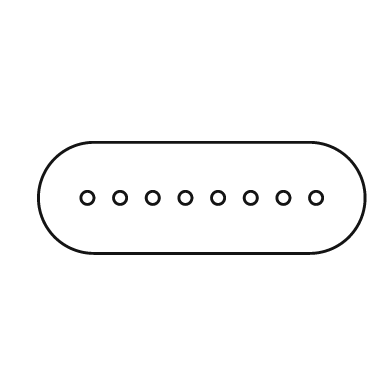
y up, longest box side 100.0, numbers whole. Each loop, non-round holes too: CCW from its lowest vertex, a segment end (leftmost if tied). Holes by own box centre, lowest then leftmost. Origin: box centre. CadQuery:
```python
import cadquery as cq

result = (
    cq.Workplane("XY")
    .moveTo(-33.0, -17.0)
    .lineTo(33.0, -17.0)
    .threePointArc((50.0, 0.0), (33.0, 17.0))
    .lineTo(-33.0, 17.0)
    .threePointArc((-50.0, 0.0), (-33.0, -17.0))
    .close()
    .moveTo(-35.0, 0.0)
    .circle(2.0)
    .moveTo(-25.0, 0.0)
    .circle(2.0)
    .moveTo(-15.0, 0.0)
    .circle(2.0)
    .moveTo(-5.0, 0.0)
    .circle(2.0)
    .moveTo(5.0, 0.0)
    .circle(2.0)
    .moveTo(15.0, 0.0)
    .circle(2.0)
    .moveTo(25.0, 0.0)
    .circle(2.0)
    .moveTo(35.0, 0.0)
    .circle(2.0)
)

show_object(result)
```